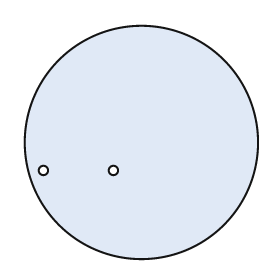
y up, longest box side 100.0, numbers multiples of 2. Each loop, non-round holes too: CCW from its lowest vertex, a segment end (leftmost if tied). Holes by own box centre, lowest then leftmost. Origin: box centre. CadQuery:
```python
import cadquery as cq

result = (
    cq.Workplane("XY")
    .moveTo(0.0, 0.0)
    .circle(50.0)
    .moveTo(-42.0, -12.0)
    .circle(2.0)
    .moveTo(-12.0, -12.0)
    .circle(2.0)
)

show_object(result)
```